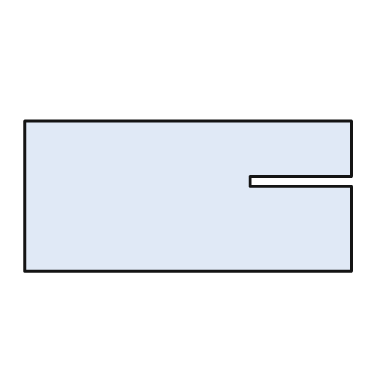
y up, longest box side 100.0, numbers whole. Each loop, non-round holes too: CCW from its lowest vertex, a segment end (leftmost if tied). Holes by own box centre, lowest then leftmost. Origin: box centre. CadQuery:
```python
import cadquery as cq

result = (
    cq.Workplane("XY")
    .moveTo(-50.0, -23.0)
    .lineTo(50.0, -23.0)
    .lineTo(50.0, 3.0)
    .lineTo(19.0, 3.0)
    .lineTo(19.0, 6.0)
    .lineTo(50.0, 6.0)
    .lineTo(50.0, 23.0)
    .lineTo(-50.0, 23.0)
    .close()
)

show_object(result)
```